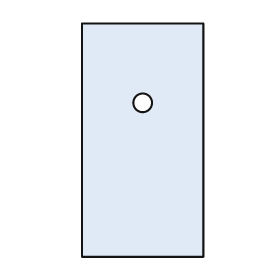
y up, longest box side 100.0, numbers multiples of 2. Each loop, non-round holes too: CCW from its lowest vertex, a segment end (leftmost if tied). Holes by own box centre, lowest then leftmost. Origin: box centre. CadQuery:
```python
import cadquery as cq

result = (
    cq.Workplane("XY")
    .moveTo(-26.0, -50.0)
    .lineTo(26.0, -50.0)
    .lineTo(26.0, 50.0)
    .lineTo(-26.0, 50.0)
    .close()
    .moveTo(0.0, 16.0)
    .circle(4.0)
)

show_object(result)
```